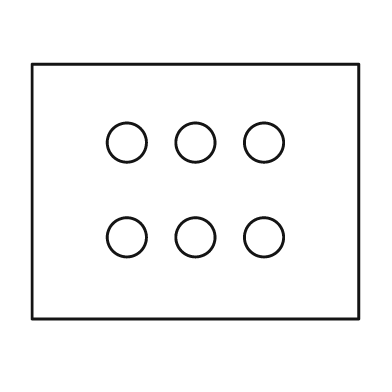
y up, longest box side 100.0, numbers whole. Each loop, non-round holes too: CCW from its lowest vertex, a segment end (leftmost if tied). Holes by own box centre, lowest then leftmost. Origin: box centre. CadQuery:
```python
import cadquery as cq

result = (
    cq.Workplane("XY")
    .moveTo(-50.0, -39.0)
    .lineTo(50.0, -39.0)
    .lineTo(50.0, 39.0)
    .lineTo(-50.0, 39.0)
    .close()
    .moveTo(-21.0, -14.0)
    .circle(6.0)
    .moveTo(0.0, -14.0)
    .circle(6.0)
    .moveTo(21.0, -14.0)
    .circle(6.0)
    .moveTo(-21.0, 15.0)
    .circle(6.0)
    .moveTo(0.0, 15.0)
    .circle(6.0)
    .moveTo(21.0, 15.0)
    .circle(6.0)
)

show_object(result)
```